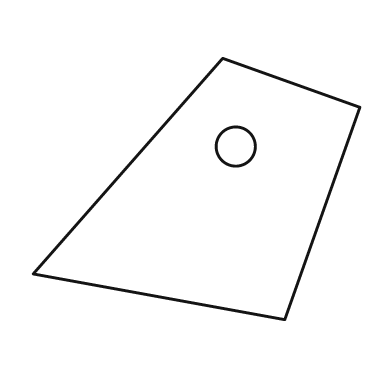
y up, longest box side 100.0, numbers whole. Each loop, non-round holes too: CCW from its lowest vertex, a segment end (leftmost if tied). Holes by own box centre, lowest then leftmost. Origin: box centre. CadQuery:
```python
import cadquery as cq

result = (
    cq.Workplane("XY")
    .moveTo(27.0, -40.0)
    .lineTo(50.0, 25.0)
    .lineTo(8.0, 40.0)
    .lineTo(-50.0, -26.0)
    .close()
    .moveTo(12.0, 13.0)
    .circle(6.0)
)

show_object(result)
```